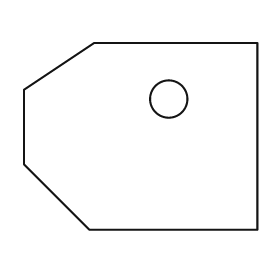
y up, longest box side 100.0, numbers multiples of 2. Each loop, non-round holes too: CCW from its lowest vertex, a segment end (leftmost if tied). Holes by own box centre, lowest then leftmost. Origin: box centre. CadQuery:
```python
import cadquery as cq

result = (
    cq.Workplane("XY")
    .moveTo(-22.0, -40.0)
    .lineTo(50.0, -40.0)
    .lineTo(50.0, 40.0)
    .lineTo(-20.0, 40.0)
    .lineTo(-50.0, 20.0)
    .lineTo(-50.0, -12.0)
    .close()
    .moveTo(12.0, 16.0)
    .circle(8.0)
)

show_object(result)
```